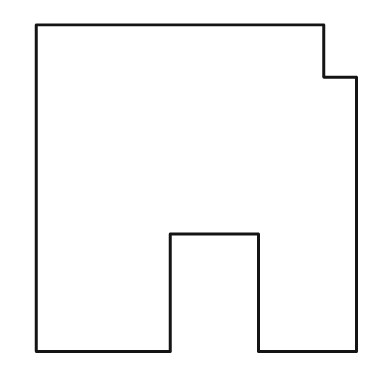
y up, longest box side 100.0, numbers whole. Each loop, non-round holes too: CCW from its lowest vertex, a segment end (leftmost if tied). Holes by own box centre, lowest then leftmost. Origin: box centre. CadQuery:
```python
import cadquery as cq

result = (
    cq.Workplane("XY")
    .moveTo(-49.0, -50.0)
    .lineTo(-8.0, -50.0)
    .lineTo(-8.0, -14.0)
    .lineTo(19.0, -14.0)
    .lineTo(19.0, -50.0)
    .lineTo(49.0, -50.0)
    .lineTo(49.0, 34.0)
    .lineTo(39.0, 34.0)
    .lineTo(39.0, 50.0)
    .lineTo(-49.0, 50.0)
    .close()
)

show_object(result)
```